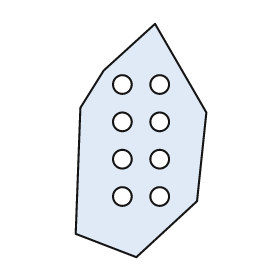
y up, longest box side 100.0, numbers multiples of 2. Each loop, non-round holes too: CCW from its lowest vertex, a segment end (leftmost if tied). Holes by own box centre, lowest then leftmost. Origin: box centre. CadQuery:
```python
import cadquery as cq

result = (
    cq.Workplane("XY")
    .moveTo(-2.0, -50.0)
    .lineTo(24.0, -26.0)
    .lineTo(28.0, 12.0)
    .lineTo(6.0, 50.0)
    .lineTo(-16.0, 30.0)
    .lineTo(-26.0, 14.0)
    .lineTo(-28.0, -40.0)
    .close()
    .moveTo(-8.0, -24.0)
    .circle(4.0)
    .moveTo(8.0, -24.0)
    .circle(4.0)
    .moveTo(-8.0, -8.0)
    .circle(4.0)
    .moveTo(8.0, -8.0)
    .circle(4.0)
    .moveTo(-8.0, 8.0)
    .circle(4.0)
    .moveTo(8.0, 8.0)
    .circle(4.0)
    .moveTo(-8.0, 24.0)
    .circle(4.0)
    .moveTo(8.0, 24.0)
    .circle(4.0)
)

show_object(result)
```